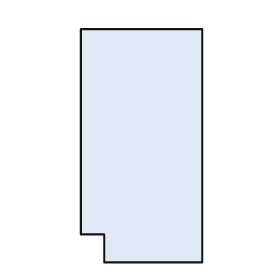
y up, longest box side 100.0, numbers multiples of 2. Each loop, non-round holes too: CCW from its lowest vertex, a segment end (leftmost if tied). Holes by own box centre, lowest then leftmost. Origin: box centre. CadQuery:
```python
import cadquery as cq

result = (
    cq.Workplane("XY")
    .moveTo(-16.0, -50.0)
    .lineTo(26.0, -50.0)
    .lineTo(26.0, 50.0)
    .lineTo(-26.0, 50.0)
    .lineTo(-26.0, -38.0)
    .lineTo(-16.0, -38.0)
    .close()
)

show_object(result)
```